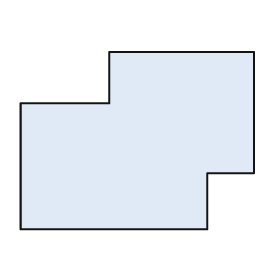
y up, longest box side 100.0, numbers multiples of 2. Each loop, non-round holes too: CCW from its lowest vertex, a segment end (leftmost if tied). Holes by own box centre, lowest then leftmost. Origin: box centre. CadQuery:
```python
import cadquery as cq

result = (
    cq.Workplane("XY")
    .moveTo(-50.0, -38.0)
    .lineTo(30.0, -38.0)
    .lineTo(30.0, -14.0)
    .lineTo(50.0, -14.0)
    .lineTo(50.0, 38.0)
    .lineTo(-12.0, 38.0)
    .lineTo(-12.0, 16.0)
    .lineTo(-50.0, 16.0)
    .close()
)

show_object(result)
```